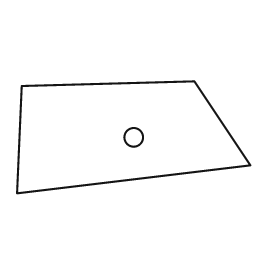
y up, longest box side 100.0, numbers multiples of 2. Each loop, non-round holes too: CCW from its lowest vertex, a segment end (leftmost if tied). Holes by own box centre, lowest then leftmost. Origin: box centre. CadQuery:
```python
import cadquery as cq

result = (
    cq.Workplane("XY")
    .moveTo(-50.0, -24.0)
    .lineTo(50.0, -12.0)
    .lineTo(26.0, 24.0)
    .lineTo(-48.0, 22.0)
    .close()
    .moveTo(0.0, 0.0)
    .circle(4.0)
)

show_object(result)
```